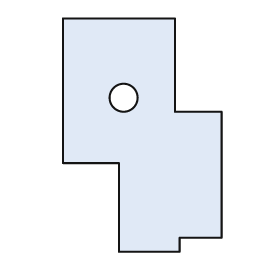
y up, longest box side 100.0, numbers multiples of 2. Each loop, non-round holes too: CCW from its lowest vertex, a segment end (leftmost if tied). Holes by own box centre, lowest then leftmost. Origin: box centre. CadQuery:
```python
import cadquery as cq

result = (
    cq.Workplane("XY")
    .moveTo(-10.0, -50.0)
    .lineTo(16.0, -50.0)
    .lineTo(16.0, -44.0)
    .lineTo(34.0, -44.0)
    .lineTo(34.0, 10.0)
    .lineTo(14.0, 10.0)
    .lineTo(14.0, 50.0)
    .lineTo(-34.0, 50.0)
    .lineTo(-34.0, -12.0)
    .lineTo(-10.0, -12.0)
    .close()
    .moveTo(-8.0, 16.0)
    .circle(6.0)
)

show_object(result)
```